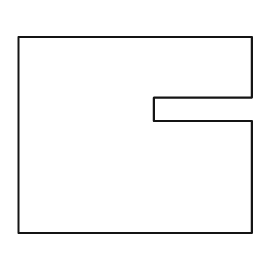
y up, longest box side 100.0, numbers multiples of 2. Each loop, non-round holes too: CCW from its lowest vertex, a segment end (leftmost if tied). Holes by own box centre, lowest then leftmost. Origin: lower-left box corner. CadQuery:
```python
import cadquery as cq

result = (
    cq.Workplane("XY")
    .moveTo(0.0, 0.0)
    .lineTo(100.0, 0.0)
    .lineTo(100.0, 48.0)
    .lineTo(58.0, 48.0)
    .lineTo(58.0, 58.0)
    .lineTo(100.0, 58.0)
    .lineTo(100.0, 84.0)
    .lineTo(0.0, 84.0)
    .close()
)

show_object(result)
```